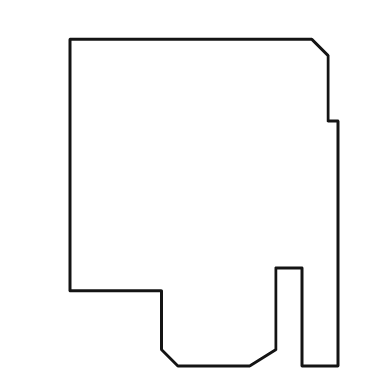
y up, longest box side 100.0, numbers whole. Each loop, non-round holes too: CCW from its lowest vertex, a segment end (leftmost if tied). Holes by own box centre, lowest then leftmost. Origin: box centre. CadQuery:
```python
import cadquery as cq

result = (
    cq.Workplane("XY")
    .moveTo(-8.0, -50.0)
    .lineTo(14.0, -50.0)
    .lineTo(22.0, -45.0)
    .lineTo(22.0, -20.0)
    .lineTo(30.0, -20.0)
    .lineTo(30.0, -50.0)
    .lineTo(41.0, -50.0)
    .lineTo(41.0, 25.0)
    .lineTo(38.0, 25.0)
    .lineTo(38.0, 45.0)
    .lineTo(33.0, 50.0)
    .lineTo(-41.0, 50.0)
    .lineTo(-41.0, -27.0)
    .lineTo(-13.0, -27.0)
    .lineTo(-13.0, -45.0)
    .close()
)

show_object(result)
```